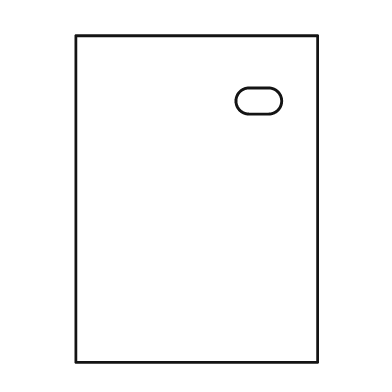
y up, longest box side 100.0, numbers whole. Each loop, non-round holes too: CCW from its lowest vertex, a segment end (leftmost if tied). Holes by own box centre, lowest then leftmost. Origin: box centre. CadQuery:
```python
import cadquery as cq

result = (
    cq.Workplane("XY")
    .moveTo(-37.0, -50.0)
    .lineTo(37.0, -50.0)
    .lineTo(37.0, 50.0)
    .lineTo(-37.0, 50.0)
    .close()
    .moveTo(16.0, 26.0)
    .lineTo(22.0, 26.0)
    .threePointArc((26.0, 30.0), (22.0, 34.0))
    .lineTo(16.0, 34.0)
    .threePointArc((12.0, 30.0), (16.0, 26.0))
    .close()
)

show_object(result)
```